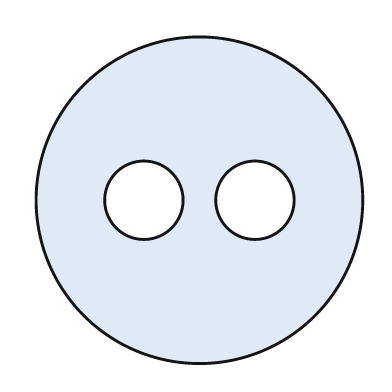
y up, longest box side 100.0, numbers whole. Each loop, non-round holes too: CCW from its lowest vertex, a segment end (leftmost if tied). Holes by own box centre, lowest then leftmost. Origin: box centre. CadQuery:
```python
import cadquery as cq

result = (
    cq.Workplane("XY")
    .moveTo(0.0, 0.0)
    .circle(50.0)
    .moveTo(-17.0, 0.0)
    .circle(12.0)
    .moveTo(17.0, 0.0)
    .circle(12.0)
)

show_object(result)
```